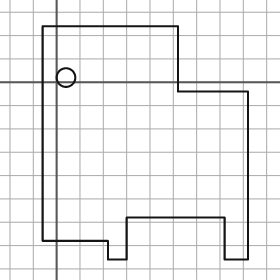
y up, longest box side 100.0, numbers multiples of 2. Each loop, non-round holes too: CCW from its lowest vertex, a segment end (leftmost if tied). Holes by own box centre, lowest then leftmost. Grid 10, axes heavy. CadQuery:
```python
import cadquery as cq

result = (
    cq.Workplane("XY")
    .moveTo(22.0, -76.0)
    .lineTo(30.0, -76.0)
    .lineTo(30.0, -58.0)
    .lineTo(72.0, -58.0)
    .lineTo(72.0, -76.0)
    .lineTo(82.0, -76.0)
    .lineTo(82.0, -4.0)
    .lineTo(52.0, -4.0)
    .lineTo(52.0, 24.0)
    .lineTo(-6.0, 24.0)
    .lineTo(-6.0, -68.0)
    .lineTo(22.0, -68.0)
    .close()
    .moveTo(4.0, 2.0)
    .circle(4.0)
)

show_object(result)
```